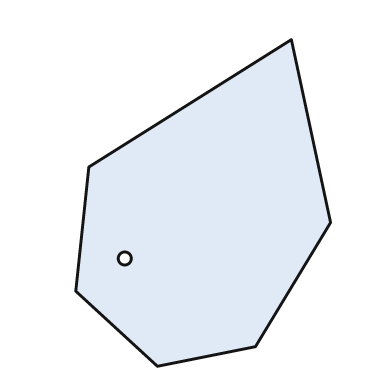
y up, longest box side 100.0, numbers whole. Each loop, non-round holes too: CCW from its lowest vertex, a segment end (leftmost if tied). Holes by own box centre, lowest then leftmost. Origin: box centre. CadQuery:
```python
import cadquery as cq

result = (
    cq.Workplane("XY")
    .moveTo(-14.0, -50.0)
    .lineTo(16.0, -44.0)
    .lineTo(39.0, -6.0)
    .lineTo(27.0, 50.0)
    .lineTo(-35.0, 11.0)
    .lineTo(-39.0, -27.0)
    .close()
    .moveTo(-24.0, -17.0)
    .circle(2.0)
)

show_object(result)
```